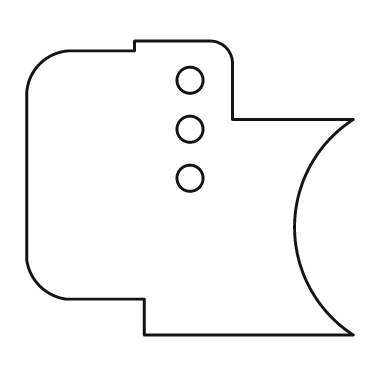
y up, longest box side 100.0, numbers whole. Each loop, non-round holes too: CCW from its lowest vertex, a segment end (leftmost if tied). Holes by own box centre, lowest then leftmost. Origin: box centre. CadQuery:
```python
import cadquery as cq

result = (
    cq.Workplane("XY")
    .moveTo(-14.0, -45.0)
    .lineTo(50.0, -45.0)
    .threePointArc((32.0, -12.0), (50.0, 21.0))
    .lineTo(13.0, 21.0)
    .lineTo(13.0, 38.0)
    .threePointArc((11.0, 43.0), (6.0, 45.0))
    .lineTo(-17.0, 45.0)
    .lineTo(-17.0, 42.0)
    .lineTo(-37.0, 42.0)
    .threePointArc((-46.0, 38.0), (-50.0, 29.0))
    .lineTo(-50.0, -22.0)
    .threePointArc((-46.0, -30.0), (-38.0, -34.0))
    .lineTo(-14.0, -34.0)
    .close()
    .moveTo(0.0, 3.0)
    .circle(4.0)
    .moveTo(0.0, 18.0)
    .circle(4.0)
    .moveTo(0.0, 33.0)
    .circle(4.0)
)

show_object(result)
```